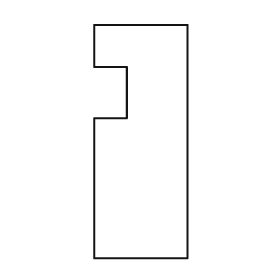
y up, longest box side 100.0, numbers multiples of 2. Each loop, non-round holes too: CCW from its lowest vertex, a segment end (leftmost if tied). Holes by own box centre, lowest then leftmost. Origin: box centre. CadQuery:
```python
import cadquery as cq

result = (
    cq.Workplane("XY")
    .moveTo(-20.0, -50.0)
    .lineTo(20.0, -50.0)
    .lineTo(20.0, 50.0)
    .lineTo(-20.0, 50.0)
    .lineTo(-20.0, 32.0)
    .lineTo(-6.0, 32.0)
    .lineTo(-6.0, 10.0)
    .lineTo(-20.0, 10.0)
    .close()
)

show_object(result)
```